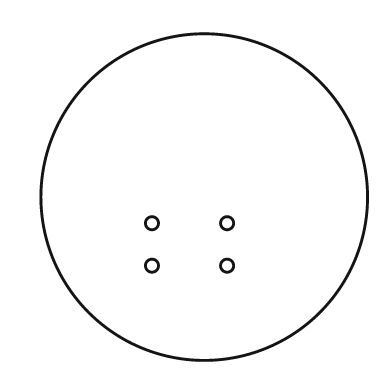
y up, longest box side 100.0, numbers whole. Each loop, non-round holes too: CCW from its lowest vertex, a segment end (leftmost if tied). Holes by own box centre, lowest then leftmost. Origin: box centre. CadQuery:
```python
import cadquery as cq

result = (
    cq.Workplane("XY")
    .moveTo(0.0, 0.0)
    .circle(50.0)
    .moveTo(-16.0, -21.0)
    .circle(2.0)
    .moveTo(7.0, -21.0)
    .circle(2.0)
    .moveTo(-16.0, -8.0)
    .circle(2.0)
    .moveTo(7.0, -8.0)
    .circle(2.0)
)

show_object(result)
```